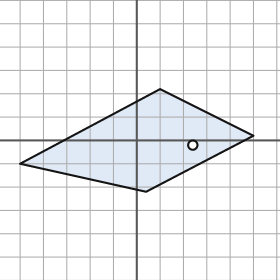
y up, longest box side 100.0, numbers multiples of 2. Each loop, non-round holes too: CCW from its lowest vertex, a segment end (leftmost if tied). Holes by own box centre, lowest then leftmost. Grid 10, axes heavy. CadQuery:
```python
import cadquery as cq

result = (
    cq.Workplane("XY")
    .moveTo(4.0, -22.0)
    .lineTo(50.0, 2.0)
    .lineTo(10.0, 22.0)
    .lineTo(-50.0, -10.0)
    .close()
    .moveTo(24.0, -2.0)
    .circle(2.0)
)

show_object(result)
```